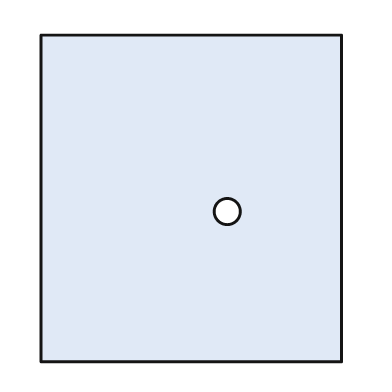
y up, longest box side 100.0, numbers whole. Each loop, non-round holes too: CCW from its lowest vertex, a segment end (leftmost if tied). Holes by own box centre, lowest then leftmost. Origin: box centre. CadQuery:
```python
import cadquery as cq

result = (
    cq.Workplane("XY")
    .moveTo(-46.0, -50.0)
    .lineTo(46.0, -50.0)
    .lineTo(46.0, 50.0)
    .lineTo(-46.0, 50.0)
    .close()
    .moveTo(11.0, -4.0)
    .circle(4.0)
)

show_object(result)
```